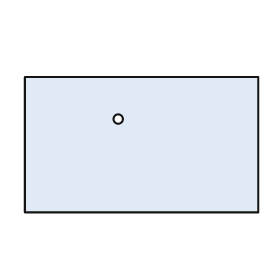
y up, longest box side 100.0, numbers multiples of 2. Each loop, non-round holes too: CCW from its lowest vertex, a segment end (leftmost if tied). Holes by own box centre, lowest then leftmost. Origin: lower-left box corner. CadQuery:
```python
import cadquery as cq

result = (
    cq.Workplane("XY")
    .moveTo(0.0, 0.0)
    .lineTo(100.0, 0.0)
    .lineTo(100.0, 58.0)
    .lineTo(0.0, 58.0)
    .close()
    .moveTo(40.0, 40.0)
    .circle(2.0)
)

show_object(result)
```